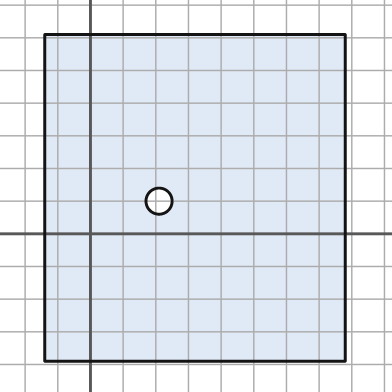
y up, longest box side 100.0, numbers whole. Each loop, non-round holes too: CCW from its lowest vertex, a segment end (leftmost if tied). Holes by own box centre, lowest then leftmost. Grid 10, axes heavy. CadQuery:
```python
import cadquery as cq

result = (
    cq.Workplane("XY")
    .moveTo(-14.0, -39.0)
    .lineTo(78.0, -39.0)
    .lineTo(78.0, 61.0)
    .lineTo(-14.0, 61.0)
    .close()
    .moveTo(21.0, 10.0)
    .circle(4.0)
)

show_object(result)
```